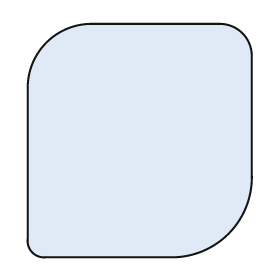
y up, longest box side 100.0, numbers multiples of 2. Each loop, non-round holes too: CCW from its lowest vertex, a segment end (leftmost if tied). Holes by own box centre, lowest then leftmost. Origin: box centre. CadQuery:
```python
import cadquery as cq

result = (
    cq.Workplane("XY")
    .moveTo(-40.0, -50.0)
    .lineTo(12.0, -50.0)
    .threePointArc((38.0, -40.0), (48.0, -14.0))
    .lineTo(48.0, 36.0)
    .threePointArc((44.0, 46.0), (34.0, 50.0))
    .lineTo(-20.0, 50.0)
    .threePointArc((-40.0, 42.0), (-48.0, 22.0))
    .lineTo(-48.0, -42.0)
    .threePointArc((-46.0, -48.0), (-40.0, -50.0))
    .close()
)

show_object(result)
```